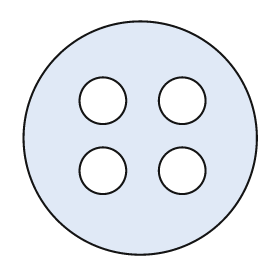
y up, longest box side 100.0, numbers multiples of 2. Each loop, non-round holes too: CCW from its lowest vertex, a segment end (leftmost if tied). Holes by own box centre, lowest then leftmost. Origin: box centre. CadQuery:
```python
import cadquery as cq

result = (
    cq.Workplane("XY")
    .moveTo(0.0, 0.0)
    .circle(50.0)
    .moveTo(-16.0, -14.0)
    .circle(10.0)
    .moveTo(18.0, -14.0)
    .circle(10.0)
    .moveTo(-16.0, 16.0)
    .circle(10.0)
    .moveTo(18.0, 16.0)
    .circle(10.0)
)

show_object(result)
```